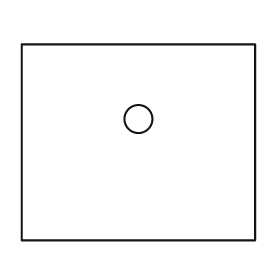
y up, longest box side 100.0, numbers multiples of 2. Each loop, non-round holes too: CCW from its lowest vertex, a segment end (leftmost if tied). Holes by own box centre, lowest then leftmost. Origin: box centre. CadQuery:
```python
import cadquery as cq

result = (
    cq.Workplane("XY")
    .moveTo(-50.0, -42.0)
    .lineTo(50.0, -42.0)
    .lineTo(50.0, 42.0)
    .lineTo(-50.0, 42.0)
    .close()
    .moveTo(0.0, 10.0)
    .circle(6.0)
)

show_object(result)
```